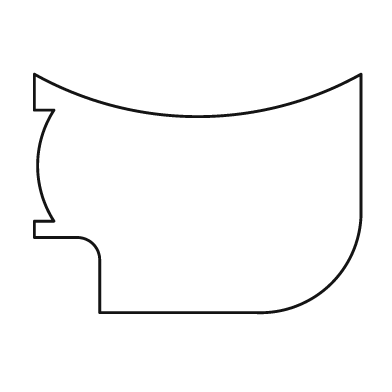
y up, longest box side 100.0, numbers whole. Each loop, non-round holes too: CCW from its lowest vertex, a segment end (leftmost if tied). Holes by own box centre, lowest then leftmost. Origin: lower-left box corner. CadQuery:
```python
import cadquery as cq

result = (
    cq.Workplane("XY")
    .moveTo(20.0, 0.0)
    .lineTo(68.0, 0.0)
    .threePointArc((91.0, 9.0), (100.0, 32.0))
    .lineTo(100.0, 73.0)
    .threePointArc((50.0, 60.0), (0.0, 73.0))
    .lineTo(0.0, 62.0)
    .lineTo(6.0, 62.0)
    .threePointArc((1.0, 45.0), (6.0, 28.0))
    .lineTo(0.0, 28.0)
    .lineTo(0.0, 23.0)
    .lineTo(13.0, 23.0)
    .threePointArc((18.0, 21.0), (20.0, 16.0))
    .close()
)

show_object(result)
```